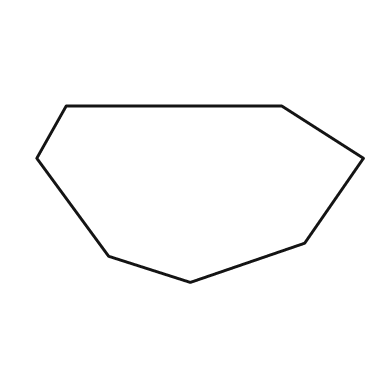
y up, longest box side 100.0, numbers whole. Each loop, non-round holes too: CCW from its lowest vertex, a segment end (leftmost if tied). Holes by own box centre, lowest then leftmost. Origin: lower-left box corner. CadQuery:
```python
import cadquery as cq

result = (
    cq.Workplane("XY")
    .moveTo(47.0, 0.0)
    .lineTo(82.0, 12.0)
    .lineTo(100.0, 38.0)
    .lineTo(75.0, 54.0)
    .lineTo(9.0, 54.0)
    .lineTo(0.0, 38.0)
    .lineTo(22.0, 8.0)
    .close()
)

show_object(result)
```